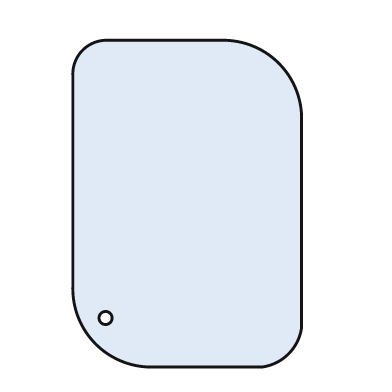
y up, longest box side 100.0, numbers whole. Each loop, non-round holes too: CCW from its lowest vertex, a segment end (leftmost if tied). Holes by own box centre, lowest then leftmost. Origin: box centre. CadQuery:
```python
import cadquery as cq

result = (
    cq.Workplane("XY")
    .moveTo(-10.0, -50.0)
    .lineTo(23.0, -50.0)
    .threePointArc((31.0, -46.0), (35.0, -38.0))
    .lineTo(35.0, 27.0)
    .threePointArc((28.0, 43.0), (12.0, 50.0))
    .lineTo(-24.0, 50.0)
    .threePointArc((-32.0, 47.0), (-35.0, 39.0))
    .lineTo(-35.0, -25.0)
    .threePointArc((-28.0, -43.0), (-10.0, -50.0))
    .close()
    .moveTo(-25.0, -35.0)
    .circle(2.0)
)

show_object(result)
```